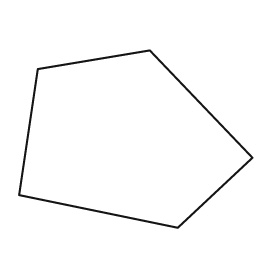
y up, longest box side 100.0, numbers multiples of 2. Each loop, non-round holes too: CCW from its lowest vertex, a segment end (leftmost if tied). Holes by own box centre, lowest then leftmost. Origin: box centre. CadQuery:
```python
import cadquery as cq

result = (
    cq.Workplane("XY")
    .moveTo(18.0, -38.0)
    .lineTo(50.0, -8.0)
    .lineTo(6.0, 38.0)
    .lineTo(-42.0, 30.0)
    .lineTo(-50.0, -24.0)
    .close()
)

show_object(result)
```